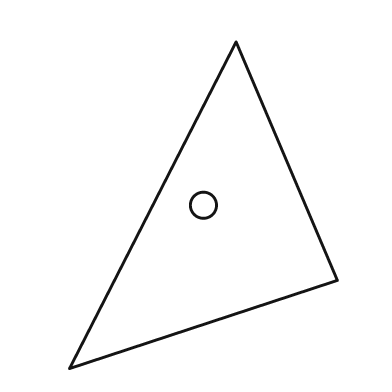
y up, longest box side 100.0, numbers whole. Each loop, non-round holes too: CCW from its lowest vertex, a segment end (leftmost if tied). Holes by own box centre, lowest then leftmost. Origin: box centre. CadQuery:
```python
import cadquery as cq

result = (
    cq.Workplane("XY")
    .moveTo(-41.0, -50.0)
    .lineTo(41.0, -23.0)
    .lineTo(10.0, 50.0)
    .close()
    .moveTo(0.0, 0.0)
    .circle(4.0)
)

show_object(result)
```